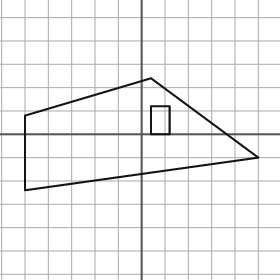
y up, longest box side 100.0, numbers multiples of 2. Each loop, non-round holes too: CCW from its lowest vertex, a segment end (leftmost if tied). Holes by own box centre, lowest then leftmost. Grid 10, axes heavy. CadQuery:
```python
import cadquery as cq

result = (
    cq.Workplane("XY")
    .moveTo(-50.0, -24.0)
    .lineTo(50.0, -10.0)
    .lineTo(4.0, 24.0)
    .lineTo(-50.0, 8.0)
    .close()
    .moveTo(4.0, 0.0)
    .lineTo(12.0, 0.0)
    .lineTo(12.0, 12.0)
    .lineTo(4.0, 12.0)
    .close()
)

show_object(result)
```